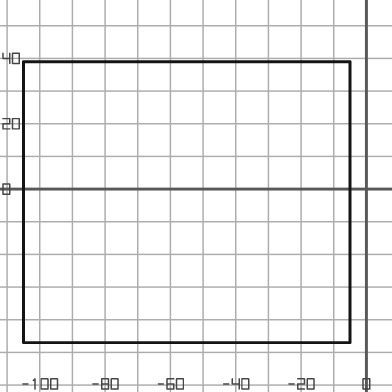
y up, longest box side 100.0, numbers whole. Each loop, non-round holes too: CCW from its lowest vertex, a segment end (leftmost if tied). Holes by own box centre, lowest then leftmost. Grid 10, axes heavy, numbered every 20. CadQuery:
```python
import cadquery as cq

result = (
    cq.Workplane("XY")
    .moveTo(-105.0, -47.0)
    .lineTo(-5.0, -47.0)
    .lineTo(-5.0, 39.0)
    .lineTo(-105.0, 39.0)
    .close()
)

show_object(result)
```